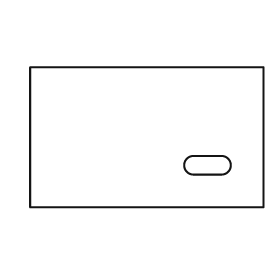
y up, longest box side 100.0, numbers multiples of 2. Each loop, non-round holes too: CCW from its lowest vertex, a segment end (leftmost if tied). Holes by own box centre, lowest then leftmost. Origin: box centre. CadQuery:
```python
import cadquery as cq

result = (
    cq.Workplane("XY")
    .moveTo(-50.0, -30.0)
    .lineTo(50.0, -30.0)
    .lineTo(50.0, 30.0)
    .lineTo(-50.0, 30.0)
    .close()
    .moveTo(20.0, -16.0)
    .lineTo(32.0, -16.0)
    .threePointArc((36.0, -12.0), (32.0, -8.0))
    .lineTo(20.0, -8.0)
    .threePointArc((16.0, -12.0), (20.0, -16.0))
    .close()
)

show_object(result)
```